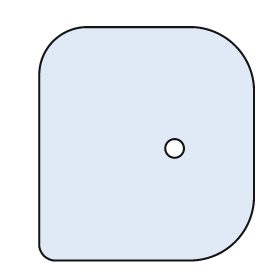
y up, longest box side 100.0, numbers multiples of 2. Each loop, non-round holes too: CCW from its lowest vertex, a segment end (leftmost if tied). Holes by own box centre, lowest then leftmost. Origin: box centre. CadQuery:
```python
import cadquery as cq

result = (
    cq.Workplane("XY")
    .moveTo(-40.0, -50.0)
    .lineTo(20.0, -50.0)
    .threePointArc((38.0, -42.0), (46.0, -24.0))
    .lineTo(46.0, 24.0)
    .threePointArc((38.0, 42.0), (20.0, 50.0))
    .lineTo(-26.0, 50.0)
    .threePointArc((-40.0, 44.0), (-46.0, 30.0))
    .lineTo(-46.0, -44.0)
    .threePointArc((-44.0, -48.0), (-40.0, -50.0))
    .close()
    .moveTo(12.0, -2.0)
    .circle(4.0)
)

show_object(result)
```